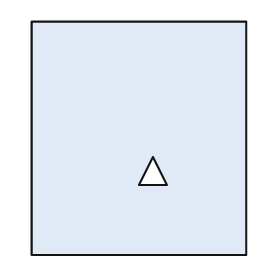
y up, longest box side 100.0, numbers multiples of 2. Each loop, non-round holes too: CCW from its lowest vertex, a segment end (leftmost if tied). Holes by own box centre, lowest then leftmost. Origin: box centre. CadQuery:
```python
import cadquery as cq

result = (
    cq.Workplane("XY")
    .moveTo(-46.0, -50.0)
    .lineTo(46.0, -50.0)
    .lineTo(46.0, 50.0)
    .lineTo(-46.0, 50.0)
    .close()
    .moveTo(0.0, -20.0)
    .lineTo(12.0, -20.0)
    .lineTo(6.0, -8.0)
    .close()
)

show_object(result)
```